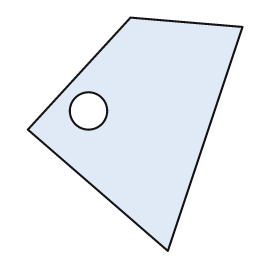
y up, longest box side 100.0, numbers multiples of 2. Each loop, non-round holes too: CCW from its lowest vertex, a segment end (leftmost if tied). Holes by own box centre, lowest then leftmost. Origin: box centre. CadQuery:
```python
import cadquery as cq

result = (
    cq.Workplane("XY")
    .moveTo(14.0, -50.0)
    .lineTo(46.0, 46.0)
    .lineTo(-2.0, 50.0)
    .lineTo(-46.0, 2.0)
    .close()
    .moveTo(-20.0, 10.0)
    .circle(8.0)
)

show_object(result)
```